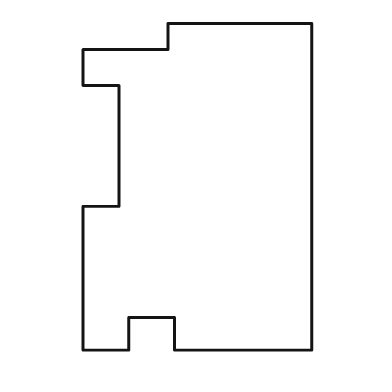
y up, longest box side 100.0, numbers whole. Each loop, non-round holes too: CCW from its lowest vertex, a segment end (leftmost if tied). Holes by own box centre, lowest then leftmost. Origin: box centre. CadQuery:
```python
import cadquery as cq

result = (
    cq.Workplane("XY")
    .moveTo(-35.0, -50.0)
    .lineTo(-21.0, -50.0)
    .lineTo(-21.0, -40.0)
    .lineTo(-7.0, -40.0)
    .lineTo(-7.0, -50.0)
    .lineTo(35.0, -50.0)
    .lineTo(35.0, 50.0)
    .lineTo(-9.0, 50.0)
    .lineTo(-9.0, 42.0)
    .lineTo(-35.0, 42.0)
    .lineTo(-35.0, 31.0)
    .lineTo(-24.0, 31.0)
    .lineTo(-24.0, -6.0)
    .lineTo(-35.0, -6.0)
    .close()
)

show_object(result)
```